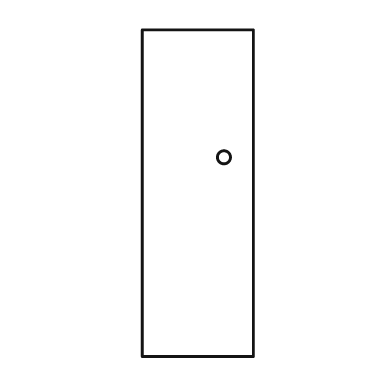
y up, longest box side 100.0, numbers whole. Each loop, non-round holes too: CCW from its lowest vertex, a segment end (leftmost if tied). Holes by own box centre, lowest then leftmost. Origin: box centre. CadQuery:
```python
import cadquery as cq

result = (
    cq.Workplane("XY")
    .moveTo(-17.0, -50.0)
    .lineTo(17.0, -50.0)
    .lineTo(17.0, 50.0)
    .lineTo(-17.0, 50.0)
    .close()
    .moveTo(8.0, 11.0)
    .circle(2.0)
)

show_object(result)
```